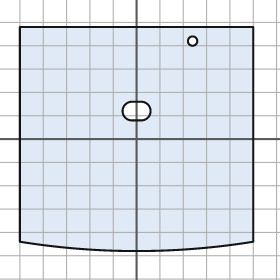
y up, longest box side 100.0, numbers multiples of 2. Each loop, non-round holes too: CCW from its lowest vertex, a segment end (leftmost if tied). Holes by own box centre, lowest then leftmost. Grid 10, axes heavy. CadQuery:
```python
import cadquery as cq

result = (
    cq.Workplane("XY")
    .moveTo(-50.0, -44.0)
    .threePointArc((0.0, -48.0), (50.0, -44.0))
    .lineTo(50.0, 48.0)
    .lineTo(-50.0, 48.0)
    .close()
    .moveTo(-2.0, 8.0)
    .lineTo(2.0, 8.0)
    .threePointArc((6.0, 12.0), (2.0, 16.0))
    .lineTo(-2.0, 16.0)
    .threePointArc((-6.0, 12.0), (-2.0, 8.0))
    .close()
    .moveTo(24.0, 42.0)
    .circle(2.0)
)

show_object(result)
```